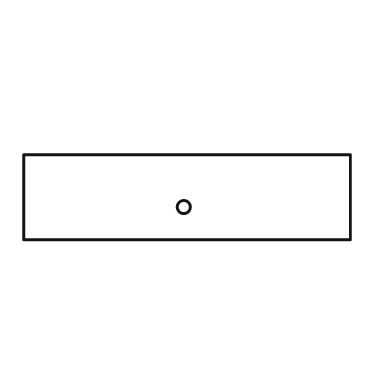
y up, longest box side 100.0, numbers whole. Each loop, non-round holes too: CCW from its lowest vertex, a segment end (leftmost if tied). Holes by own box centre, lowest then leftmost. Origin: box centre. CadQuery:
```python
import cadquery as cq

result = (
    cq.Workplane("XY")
    .moveTo(-50.0, -13.0)
    .lineTo(50.0, -13.0)
    .lineTo(50.0, 13.0)
    .lineTo(-50.0, 13.0)
    .close()
    .moveTo(-1.0, -3.0)
    .circle(2.0)
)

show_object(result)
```